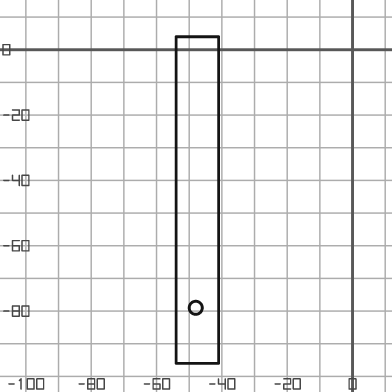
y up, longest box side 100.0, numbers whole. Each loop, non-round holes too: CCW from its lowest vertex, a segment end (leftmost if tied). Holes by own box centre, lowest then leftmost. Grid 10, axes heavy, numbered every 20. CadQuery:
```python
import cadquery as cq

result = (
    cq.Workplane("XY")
    .moveTo(-54.0, -96.0)
    .lineTo(-41.0, -96.0)
    .lineTo(-41.0, 4.0)
    .lineTo(-54.0, 4.0)
    .close()
    .moveTo(-48.0, -79.0)
    .circle(2.0)
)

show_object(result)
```